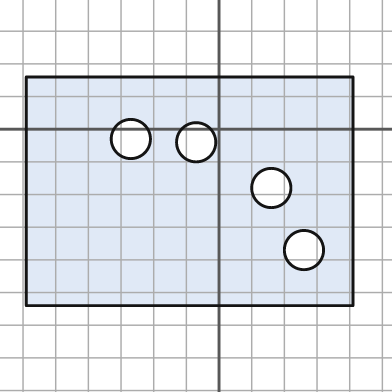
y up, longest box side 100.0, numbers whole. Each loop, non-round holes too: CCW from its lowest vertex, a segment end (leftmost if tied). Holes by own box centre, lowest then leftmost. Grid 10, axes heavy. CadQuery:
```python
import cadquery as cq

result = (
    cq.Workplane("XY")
    .moveTo(-59.0, -54.0)
    .lineTo(41.0, -54.0)
    .lineTo(41.0, 16.0)
    .lineTo(-59.0, 16.0)
    .close()
    .moveTo(26.0, -37.0)
    .circle(6.0)
    .moveTo(16.0, -18.0)
    .circle(6.0)
    .moveTo(-7.0, -4.0)
    .circle(6.0)
    .moveTo(-27.0, -3.0)
    .circle(6.0)
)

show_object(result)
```